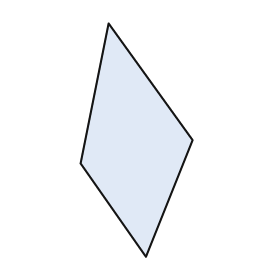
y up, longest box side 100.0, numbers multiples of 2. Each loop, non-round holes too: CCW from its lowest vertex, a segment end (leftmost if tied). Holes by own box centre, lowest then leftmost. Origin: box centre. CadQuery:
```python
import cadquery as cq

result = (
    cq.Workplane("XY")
    .moveTo(4.0, -50.0)
    .lineTo(24.0, 0.0)
    .lineTo(-12.0, 50.0)
    .lineTo(-24.0, -10.0)
    .close()
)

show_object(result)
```